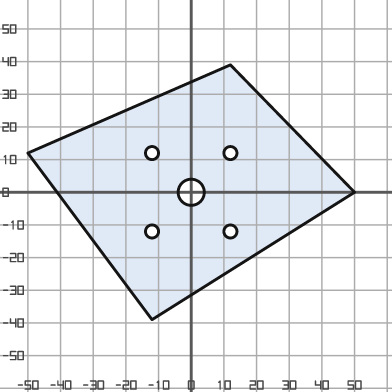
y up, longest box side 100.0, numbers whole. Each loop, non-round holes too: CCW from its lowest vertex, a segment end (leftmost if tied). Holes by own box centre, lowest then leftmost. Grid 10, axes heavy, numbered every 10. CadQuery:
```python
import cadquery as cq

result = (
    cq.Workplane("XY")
    .moveTo(-12.0, -39.0)
    .lineTo(50.0, 0.0)
    .lineTo(12.0, 39.0)
    .lineTo(-50.0, 12.0)
    .close()
    .moveTo(-12.0, -12.0)
    .circle(2.0)
    .moveTo(12.0, -12.0)
    .circle(2.0)
    .moveTo(0.0, 0.0)
    .circle(4.0)
    .moveTo(-12.0, 12.0)
    .circle(2.0)
    .moveTo(12.0, 12.0)
    .circle(2.0)
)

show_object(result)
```